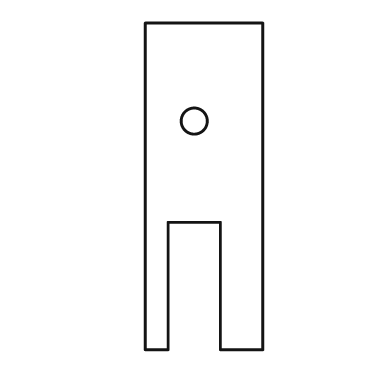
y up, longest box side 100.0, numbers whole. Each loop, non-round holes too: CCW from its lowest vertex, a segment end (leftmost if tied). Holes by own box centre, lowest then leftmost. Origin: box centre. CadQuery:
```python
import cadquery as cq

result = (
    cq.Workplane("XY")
    .moveTo(-18.0, -50.0)
    .lineTo(-11.0, -50.0)
    .lineTo(-11.0, -11.0)
    .lineTo(5.0, -11.0)
    .lineTo(5.0, -50.0)
    .lineTo(18.0, -50.0)
    .lineTo(18.0, 50.0)
    .lineTo(-18.0, 50.0)
    .close()
    .moveTo(-3.0, 20.0)
    .circle(4.0)
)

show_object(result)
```